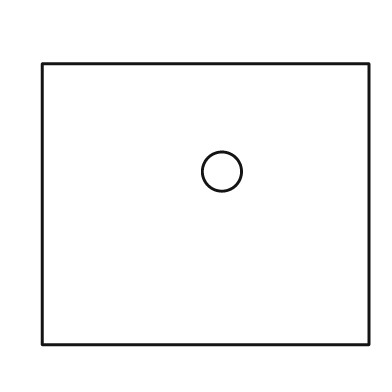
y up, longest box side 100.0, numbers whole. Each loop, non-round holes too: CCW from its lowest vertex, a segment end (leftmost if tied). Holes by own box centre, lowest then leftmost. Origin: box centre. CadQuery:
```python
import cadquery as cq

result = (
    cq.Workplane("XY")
    .moveTo(-50.0, -43.0)
    .lineTo(50.0, -43.0)
    .lineTo(50.0, 43.0)
    .lineTo(-50.0, 43.0)
    .close()
    .moveTo(5.0, 10.0)
    .circle(6.0)
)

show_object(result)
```